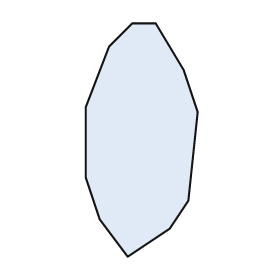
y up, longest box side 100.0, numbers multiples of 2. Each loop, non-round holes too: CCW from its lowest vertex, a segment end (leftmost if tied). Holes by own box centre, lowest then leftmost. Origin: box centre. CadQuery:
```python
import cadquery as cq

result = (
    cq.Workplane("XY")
    .moveTo(-6.0, -50.0)
    .lineTo(12.0, -38.0)
    .lineTo(20.0, -26.0)
    .lineTo(24.0, 12.0)
    .lineTo(18.0, 30.0)
    .lineTo(6.0, 50.0)
    .lineTo(-4.0, 50.0)
    .lineTo(-14.0, 40.0)
    .lineTo(-24.0, 14.0)
    .lineTo(-24.0, -16.0)
    .lineTo(-18.0, -34.0)
    .close()
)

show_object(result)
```